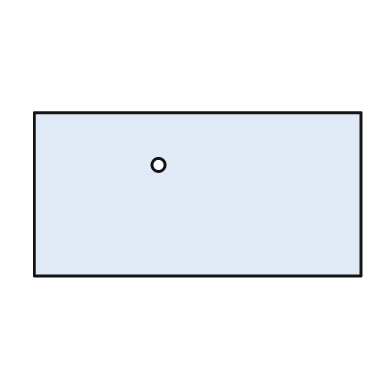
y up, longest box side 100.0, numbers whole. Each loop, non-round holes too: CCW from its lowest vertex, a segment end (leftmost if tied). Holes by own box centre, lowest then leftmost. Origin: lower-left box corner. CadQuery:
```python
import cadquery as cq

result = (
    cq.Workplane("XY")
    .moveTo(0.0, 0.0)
    .lineTo(100.0, 0.0)
    .lineTo(100.0, 50.0)
    .lineTo(0.0, 50.0)
    .close()
    .moveTo(38.0, 34.0)
    .circle(2.0)
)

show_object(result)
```